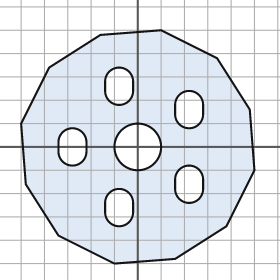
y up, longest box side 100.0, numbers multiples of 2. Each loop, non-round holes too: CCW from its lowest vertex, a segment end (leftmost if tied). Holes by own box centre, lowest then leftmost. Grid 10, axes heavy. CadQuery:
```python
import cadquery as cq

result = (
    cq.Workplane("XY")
    .moveTo(-10.0, -50.0)
    .lineTo(16.0, -48.0)
    .lineTo(38.0, -34.0)
    .lineTo(50.0, -10.0)
    .lineTo(48.0, 16.0)
    .lineTo(34.0, 38.0)
    .lineTo(10.0, 50.0)
    .lineTo(-16.0, 48.0)
    .lineTo(-38.0, 34.0)
    .lineTo(-50.0, 10.0)
    .lineTo(-48.0, -16.0)
    .lineTo(-34.0, -38.0)
    .close()
    .moveTo(-14.0, -28.0)
    .threePointArc((-8.0, -34.0), (-2.0, -28.0))
    .lineTo(-2.0, -24.0)
    .threePointArc((-8.0, -18.0), (-14.0, -24.0))
    .close()
    .moveTo(16.0, -18.0)
    .threePointArc((22.0, -24.0), (28.0, -18.0))
    .lineTo(28.0, -14.0)
    .threePointArc((22.0, -8.0), (16.0, -14.0))
    .close()
    .moveTo(-34.0, -2.0)
    .threePointArc((-28.0, -8.0), (-22.0, -2.0))
    .lineTo(-22.0, 2.0)
    .threePointArc((-28.0, 8.0), (-34.0, 2.0))
    .close()
    .moveTo(0.0, 0.0)
    .circle(10.0)
    .moveTo(16.0, 14.0)
    .threePointArc((22.0, 8.0), (28.0, 14.0))
    .lineTo(28.0, 18.0)
    .threePointArc((22.0, 24.0), (16.0, 18.0))
    .close()
    .moveTo(-14.0, 24.0)
    .threePointArc((-8.0, 18.0), (-2.0, 24.0))
    .lineTo(-2.0, 28.0)
    .threePointArc((-8.0, 34.0), (-14.0, 28.0))
    .close()
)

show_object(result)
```